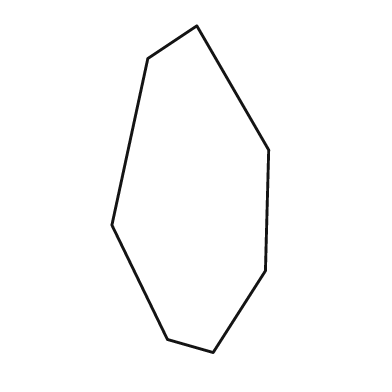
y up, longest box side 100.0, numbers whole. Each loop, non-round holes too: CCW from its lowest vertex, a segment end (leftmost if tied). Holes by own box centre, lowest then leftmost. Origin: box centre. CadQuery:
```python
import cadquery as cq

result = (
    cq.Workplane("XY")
    .moveTo(7.0, -50.0)
    .lineTo(23.0, -25.0)
    .lineTo(24.0, 12.0)
    .lineTo(2.0, 50.0)
    .lineTo(-13.0, 40.0)
    .lineTo(-24.0, -11.0)
    .lineTo(-7.0, -46.0)
    .close()
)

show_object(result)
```